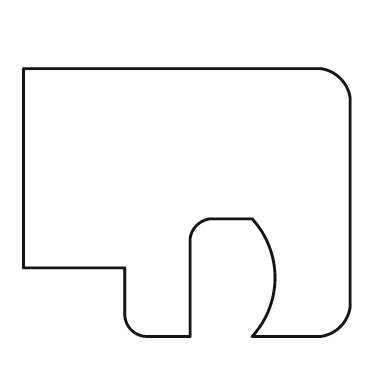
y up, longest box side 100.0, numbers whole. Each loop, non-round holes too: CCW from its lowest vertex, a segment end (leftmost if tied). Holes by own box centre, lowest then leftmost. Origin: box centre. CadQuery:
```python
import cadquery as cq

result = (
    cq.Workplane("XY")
    .moveTo(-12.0, -41.0)
    .lineTo(1.0, -41.0)
    .lineTo(1.0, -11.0)
    .threePointArc((3.0, -7.0), (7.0, -5.0))
    .lineTo(20.0, -5.0)
    .threePointArc((27.0, -23.0), (20.0, -41.0))
    .lineTo(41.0, -41.0)
    .threePointArc((47.0, -38.0), (50.0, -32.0))
    .lineTo(50.0, 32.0)
    .threePointArc((47.0, 38.0), (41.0, 41.0))
    .lineTo(-50.0, 41.0)
    .lineTo(-50.0, -20.0)
    .lineTo(-19.0, -20.0)
    .lineTo(-19.0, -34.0)
    .threePointArc((-17.0, -39.0), (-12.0, -41.0))
    .close()
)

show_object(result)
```